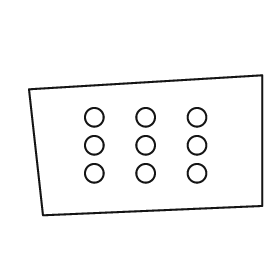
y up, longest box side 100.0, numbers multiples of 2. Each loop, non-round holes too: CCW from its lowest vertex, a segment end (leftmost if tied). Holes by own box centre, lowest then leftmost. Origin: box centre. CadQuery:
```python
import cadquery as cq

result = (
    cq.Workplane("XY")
    .moveTo(-44.0, -30.0)
    .lineTo(50.0, -26.0)
    .lineTo(50.0, 30.0)
    .lineTo(-50.0, 24.0)
    .close()
    .moveTo(-22.0, -12.0)
    .circle(4.0)
    .moveTo(0.0, -12.0)
    .circle(4.0)
    .moveTo(22.0, -12.0)
    .circle(4.0)
    .moveTo(-22.0, 0.0)
    .circle(4.0)
    .moveTo(0.0, 0.0)
    .circle(4.0)
    .moveTo(22.0, 0.0)
    .circle(4.0)
    .moveTo(-22.0, 12.0)
    .circle(4.0)
    .moveTo(0.0, 12.0)
    .circle(4.0)
    .moveTo(22.0, 12.0)
    .circle(4.0)
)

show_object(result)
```